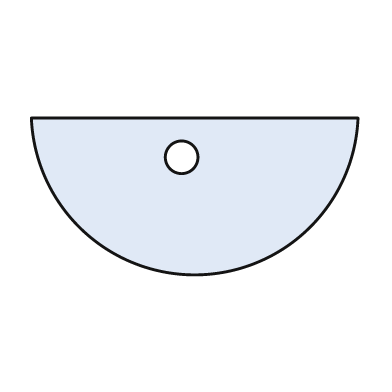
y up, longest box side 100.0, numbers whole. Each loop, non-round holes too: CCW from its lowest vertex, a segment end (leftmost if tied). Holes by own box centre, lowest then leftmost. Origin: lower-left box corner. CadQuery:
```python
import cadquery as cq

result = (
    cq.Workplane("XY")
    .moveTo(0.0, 48.0)
    .threePointArc((50.0, 0.0), (100.0, 48.0))
    .close()
    .moveTo(46.0, 36.0)
    .circle(5.0)
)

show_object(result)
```